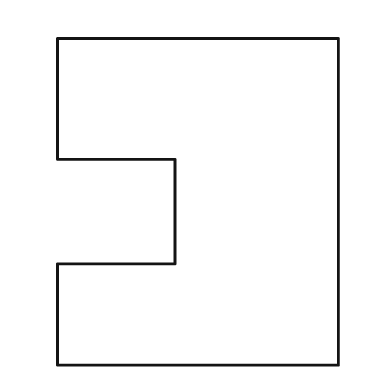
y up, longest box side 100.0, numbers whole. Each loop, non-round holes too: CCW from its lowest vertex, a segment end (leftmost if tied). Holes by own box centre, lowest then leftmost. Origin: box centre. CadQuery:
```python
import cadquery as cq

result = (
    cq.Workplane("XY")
    .moveTo(-43.0, -50.0)
    .lineTo(43.0, -50.0)
    .lineTo(43.0, 50.0)
    .lineTo(-43.0, 50.0)
    .lineTo(-43.0, 13.0)
    .lineTo(-7.0, 13.0)
    .lineTo(-7.0, -19.0)
    .lineTo(-43.0, -19.0)
    .close()
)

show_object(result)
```